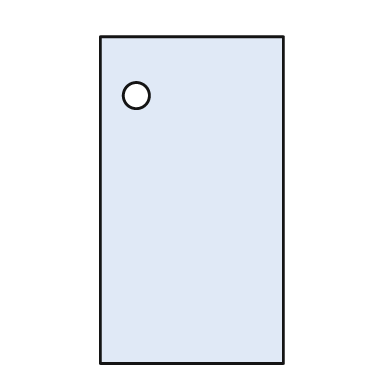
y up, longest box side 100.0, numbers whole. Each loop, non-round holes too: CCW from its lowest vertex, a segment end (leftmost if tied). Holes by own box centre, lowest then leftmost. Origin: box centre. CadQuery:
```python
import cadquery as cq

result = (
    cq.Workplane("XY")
    .moveTo(-28.0, -50.0)
    .lineTo(28.0, -50.0)
    .lineTo(28.0, 50.0)
    .lineTo(-28.0, 50.0)
    .close()
    .moveTo(-17.0, 32.0)
    .circle(4.0)
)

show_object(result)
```